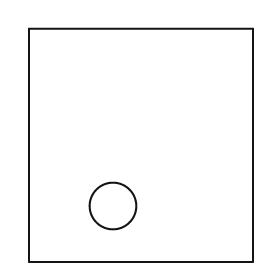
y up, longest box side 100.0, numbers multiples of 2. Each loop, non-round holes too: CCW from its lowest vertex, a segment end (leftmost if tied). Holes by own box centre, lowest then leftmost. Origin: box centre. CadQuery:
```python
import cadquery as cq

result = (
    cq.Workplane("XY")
    .moveTo(-48.0, -50.0)
    .lineTo(48.0, -50.0)
    .lineTo(48.0, 50.0)
    .lineTo(-48.0, 50.0)
    .close()
    .moveTo(-12.0, -26.0)
    .circle(10.0)
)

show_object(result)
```